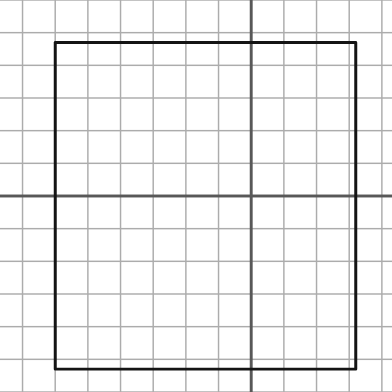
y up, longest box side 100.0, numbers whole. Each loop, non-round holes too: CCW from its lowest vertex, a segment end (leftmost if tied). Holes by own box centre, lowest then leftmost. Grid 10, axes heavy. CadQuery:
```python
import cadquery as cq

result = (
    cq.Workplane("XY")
    .moveTo(-60.0, -53.0)
    .lineTo(32.0, -53.0)
    .lineTo(32.0, 47.0)
    .lineTo(-60.0, 47.0)
    .close()
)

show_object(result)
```